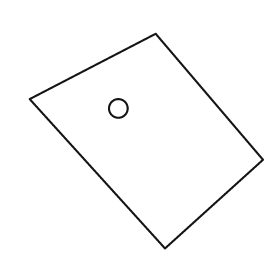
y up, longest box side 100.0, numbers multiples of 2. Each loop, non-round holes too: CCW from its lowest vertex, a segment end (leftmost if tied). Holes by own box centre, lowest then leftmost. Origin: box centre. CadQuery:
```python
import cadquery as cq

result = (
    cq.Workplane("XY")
    .moveTo(8.0, -46.0)
    .lineTo(50.0, -8.0)
    .lineTo(4.0, 46.0)
    .lineTo(-50.0, 18.0)
    .close()
    .moveTo(-12.0, 14.0)
    .circle(4.0)
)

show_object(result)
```